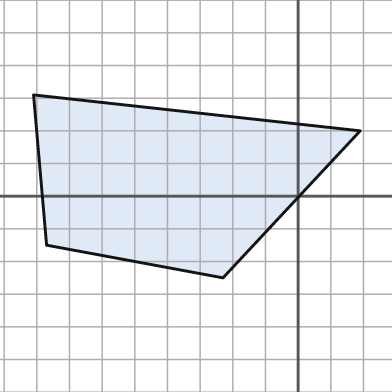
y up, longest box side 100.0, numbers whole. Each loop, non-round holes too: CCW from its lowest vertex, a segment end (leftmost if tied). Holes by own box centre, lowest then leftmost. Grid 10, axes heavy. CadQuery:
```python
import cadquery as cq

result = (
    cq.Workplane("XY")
    .moveTo(-23.0, -25.0)
    .lineTo(19.0, 20.0)
    .lineTo(-81.0, 31.0)
    .lineTo(-77.0, -15.0)
    .close()
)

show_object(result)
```